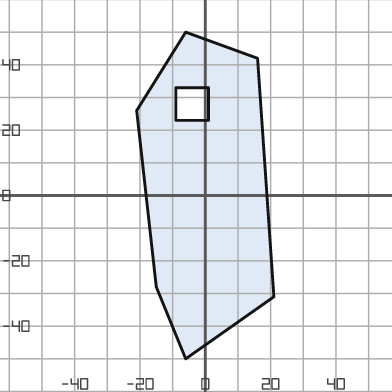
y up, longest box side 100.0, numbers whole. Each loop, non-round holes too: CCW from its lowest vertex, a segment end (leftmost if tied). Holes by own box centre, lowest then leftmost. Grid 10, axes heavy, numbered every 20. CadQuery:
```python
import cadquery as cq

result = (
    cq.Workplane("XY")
    .moveTo(-6.0, -50.0)
    .lineTo(21.0, -31.0)
    .lineTo(16.0, 42.0)
    .lineTo(-6.0, 50.0)
    .lineTo(-21.0, 26.0)
    .lineTo(-15.0, -28.0)
    .close()
    .moveTo(-9.0, 23.0)
    .lineTo(1.0, 23.0)
    .lineTo(1.0, 33.0)
    .lineTo(-9.0, 33.0)
    .close()
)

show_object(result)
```